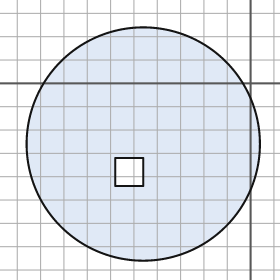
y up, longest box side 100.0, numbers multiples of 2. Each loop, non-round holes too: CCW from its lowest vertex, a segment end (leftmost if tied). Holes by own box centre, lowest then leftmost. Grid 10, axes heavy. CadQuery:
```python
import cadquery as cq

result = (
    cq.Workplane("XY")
    .moveTo(-46.0, -26.0)
    .circle(50.0)
    .moveTo(-58.0, -44.0)
    .lineTo(-46.0, -44.0)
    .lineTo(-46.0, -32.0)
    .lineTo(-58.0, -32.0)
    .close()
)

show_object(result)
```